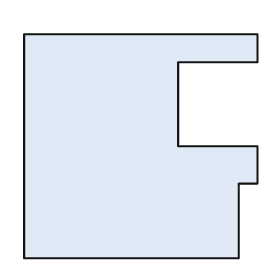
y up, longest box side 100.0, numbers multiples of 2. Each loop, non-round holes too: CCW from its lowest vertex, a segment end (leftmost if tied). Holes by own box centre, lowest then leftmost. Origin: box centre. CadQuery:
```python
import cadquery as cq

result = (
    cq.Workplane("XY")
    .moveTo(-50.0, -48.0)
    .lineTo(42.0, -48.0)
    .lineTo(42.0, -16.0)
    .lineTo(50.0, -16.0)
    .lineTo(50.0, 0.0)
    .lineTo(16.0, 0.0)
    .lineTo(16.0, 36.0)
    .lineTo(50.0, 36.0)
    .lineTo(50.0, 48.0)
    .lineTo(-50.0, 48.0)
    .close()
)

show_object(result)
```